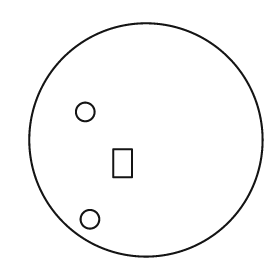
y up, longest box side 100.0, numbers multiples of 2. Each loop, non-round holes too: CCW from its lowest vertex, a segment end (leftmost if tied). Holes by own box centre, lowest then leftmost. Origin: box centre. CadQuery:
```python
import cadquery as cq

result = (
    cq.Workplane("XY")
    .moveTo(0.0, 0.0)
    .circle(50.0)
    .moveTo(-24.0, -34.0)
    .circle(4.0)
    .moveTo(-14.0, -16.0)
    .lineTo(-6.0, -16.0)
    .lineTo(-6.0, -4.0)
    .lineTo(-14.0, -4.0)
    .close()
    .moveTo(-26.0, 12.0)
    .circle(4.0)
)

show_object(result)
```